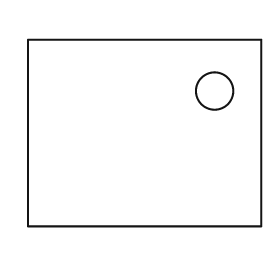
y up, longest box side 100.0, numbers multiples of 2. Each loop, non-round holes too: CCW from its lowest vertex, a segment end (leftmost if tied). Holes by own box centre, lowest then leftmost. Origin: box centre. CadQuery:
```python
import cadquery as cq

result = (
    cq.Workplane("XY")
    .moveTo(-50.0, -40.0)
    .lineTo(50.0, -40.0)
    .lineTo(50.0, 40.0)
    .lineTo(-50.0, 40.0)
    .close()
    .moveTo(30.0, 18.0)
    .circle(8.0)
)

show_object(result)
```